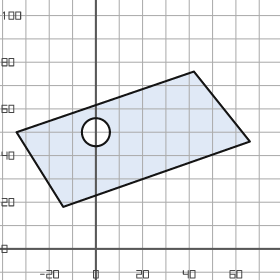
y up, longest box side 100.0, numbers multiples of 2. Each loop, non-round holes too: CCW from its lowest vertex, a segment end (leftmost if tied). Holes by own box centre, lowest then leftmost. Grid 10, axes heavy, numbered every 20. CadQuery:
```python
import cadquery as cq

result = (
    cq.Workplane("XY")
    .moveTo(-14.0, 18.0)
    .lineTo(66.0, 46.0)
    .lineTo(42.0, 76.0)
    .lineTo(-34.0, 50.0)
    .close()
    .moveTo(0.0, 50.0)
    .circle(6.0)
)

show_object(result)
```